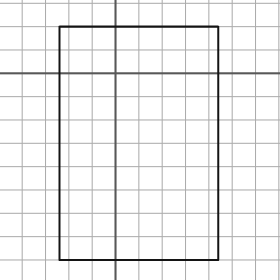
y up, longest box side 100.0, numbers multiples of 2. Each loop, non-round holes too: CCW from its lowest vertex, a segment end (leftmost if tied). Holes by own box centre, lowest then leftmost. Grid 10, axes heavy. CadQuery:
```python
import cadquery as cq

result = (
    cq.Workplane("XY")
    .moveTo(-24.0, -80.0)
    .lineTo(44.0, -80.0)
    .lineTo(44.0, 20.0)
    .lineTo(-24.0, 20.0)
    .close()
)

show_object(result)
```